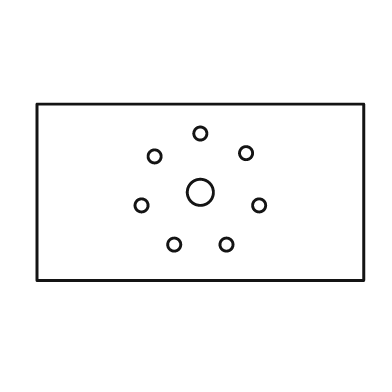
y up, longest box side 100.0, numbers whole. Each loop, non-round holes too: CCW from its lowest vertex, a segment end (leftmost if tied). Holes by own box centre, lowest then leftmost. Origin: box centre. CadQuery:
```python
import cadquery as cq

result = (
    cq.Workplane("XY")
    .moveTo(-50.0, -27.0)
    .lineTo(50.0, -27.0)
    .lineTo(50.0, 27.0)
    .lineTo(-50.0, 27.0)
    .close()
    .moveTo(-8.0, -16.0)
    .circle(2.0)
    .moveTo(8.0, -16.0)
    .circle(2.0)
    .moveTo(-18.0, -4.0)
    .circle(2.0)
    .moveTo(18.0, -4.0)
    .circle(2.0)
    .moveTo(0.0, 0.0)
    .circle(4.0)
    .moveTo(-14.0, 11.0)
    .circle(2.0)
    .moveTo(14.0, 12.0)
    .circle(2.0)
    .moveTo(0.0, 18.0)
    .circle(2.0)
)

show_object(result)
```